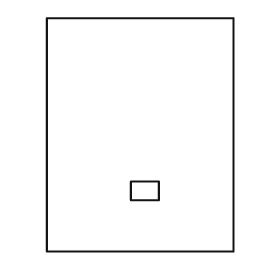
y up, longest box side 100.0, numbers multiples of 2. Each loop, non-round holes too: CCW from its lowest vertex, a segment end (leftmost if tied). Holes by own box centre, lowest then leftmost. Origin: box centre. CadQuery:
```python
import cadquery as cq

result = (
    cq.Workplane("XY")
    .moveTo(-40.0, -50.0)
    .lineTo(40.0, -50.0)
    .lineTo(40.0, 50.0)
    .lineTo(-40.0, 50.0)
    .close()
    .moveTo(-4.0, -28.0)
    .lineTo(8.0, -28.0)
    .lineTo(8.0, -20.0)
    .lineTo(-4.0, -20.0)
    .close()
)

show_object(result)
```